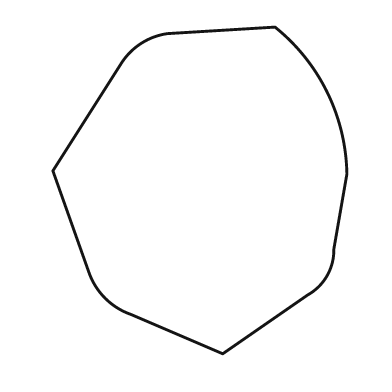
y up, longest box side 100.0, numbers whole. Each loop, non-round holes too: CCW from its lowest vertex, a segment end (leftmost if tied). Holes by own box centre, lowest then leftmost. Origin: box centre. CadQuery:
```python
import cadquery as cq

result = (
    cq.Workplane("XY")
    .moveTo(7.0, -50.0)
    .lineTo(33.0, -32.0)
    .threePointArc((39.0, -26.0), (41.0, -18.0))
    .lineTo(45.0, 5.0)
    .threePointArc((39.0, 30.0), (23.0, 50.0))
    .lineTo(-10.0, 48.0)
    .threePointArc((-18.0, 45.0), (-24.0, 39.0))
    .lineTo(-45.0, 6.0)
    .lineTo(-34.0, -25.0)
    .threePointArc((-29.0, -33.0), (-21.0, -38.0))
    .close()
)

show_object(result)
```